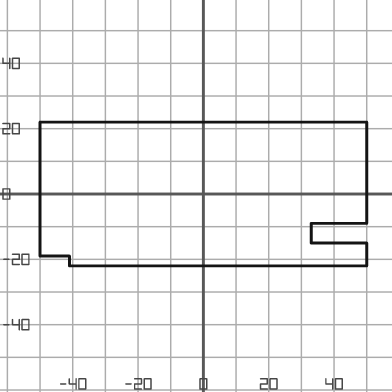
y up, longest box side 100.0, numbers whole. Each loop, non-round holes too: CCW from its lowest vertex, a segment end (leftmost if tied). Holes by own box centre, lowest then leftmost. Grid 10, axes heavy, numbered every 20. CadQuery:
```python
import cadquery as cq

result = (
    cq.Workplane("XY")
    .moveTo(-41.0, -22.0)
    .lineTo(50.0, -22.0)
    .lineTo(50.0, -15.0)
    .lineTo(33.0, -15.0)
    .lineTo(33.0, -9.0)
    .lineTo(50.0, -9.0)
    .lineTo(50.0, 22.0)
    .lineTo(-50.0, 22.0)
    .lineTo(-50.0, -19.0)
    .lineTo(-41.0, -19.0)
    .close()
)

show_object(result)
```